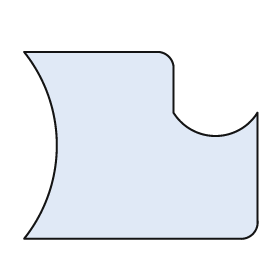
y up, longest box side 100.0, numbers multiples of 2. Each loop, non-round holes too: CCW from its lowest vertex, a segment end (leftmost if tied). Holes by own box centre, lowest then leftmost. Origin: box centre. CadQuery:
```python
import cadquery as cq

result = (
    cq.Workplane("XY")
    .moveTo(-50.0, -40.0)
    .lineTo(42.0, -40.0)
    .threePointArc((48.0, -38.0), (50.0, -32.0))
    .lineTo(50.0, 14.0)
    .threePointArc((32.0, 4.0), (14.0, 14.0))
    .lineTo(14.0, 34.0)
    .threePointArc((12.0, 38.0), (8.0, 40.0))
    .lineTo(-50.0, 40.0)
    .threePointArc((-36.0, 0.0), (-50.0, -40.0))
    .close()
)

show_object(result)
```